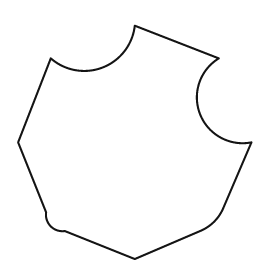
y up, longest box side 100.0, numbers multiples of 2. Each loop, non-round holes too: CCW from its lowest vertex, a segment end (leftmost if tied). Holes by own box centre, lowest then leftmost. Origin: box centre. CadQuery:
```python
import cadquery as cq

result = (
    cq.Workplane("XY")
    .moveTo(0.0, -50.0)
    .lineTo(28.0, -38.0)
    .threePointArc((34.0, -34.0), (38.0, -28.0))
    .lineTo(50.0, 0.0)
    .threePointArc((28.0, 12.0), (36.0, 36.0))
    .lineTo(0.0, 50.0)
    .threePointArc((-14.0, 32.0), (-36.0, 36.0))
    .lineTo(-50.0, 0.0)
    .lineTo(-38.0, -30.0)
    .threePointArc((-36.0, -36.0), (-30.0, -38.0))
    .close()
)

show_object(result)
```